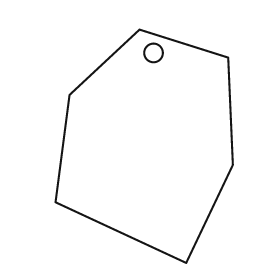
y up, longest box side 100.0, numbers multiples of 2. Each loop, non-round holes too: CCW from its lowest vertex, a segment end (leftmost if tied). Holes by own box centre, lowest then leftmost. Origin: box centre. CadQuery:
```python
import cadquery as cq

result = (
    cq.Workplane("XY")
    .moveTo(18.0, -50.0)
    .lineTo(38.0, -8.0)
    .lineTo(36.0, 38.0)
    .lineTo(-2.0, 50.0)
    .lineTo(-32.0, 22.0)
    .lineTo(-38.0, -24.0)
    .close()
    .moveTo(4.0, 40.0)
    .circle(4.0)
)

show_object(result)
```